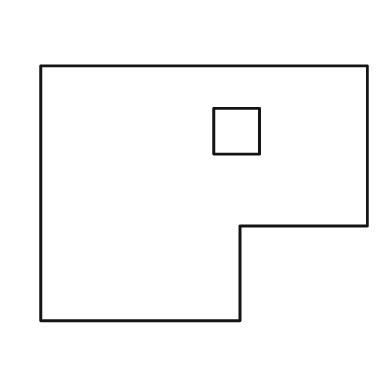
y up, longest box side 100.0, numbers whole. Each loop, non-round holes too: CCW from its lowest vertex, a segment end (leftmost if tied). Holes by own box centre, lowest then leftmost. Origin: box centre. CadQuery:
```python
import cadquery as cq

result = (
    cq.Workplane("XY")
    .moveTo(-50.0, -39.0)
    .lineTo(11.0, -39.0)
    .lineTo(11.0, -10.0)
    .lineTo(50.0, -10.0)
    .lineTo(50.0, 39.0)
    .lineTo(-50.0, 39.0)
    .close()
    .moveTo(3.0, 12.0)
    .lineTo(17.0, 12.0)
    .lineTo(17.0, 26.0)
    .lineTo(3.0, 26.0)
    .close()
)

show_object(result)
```